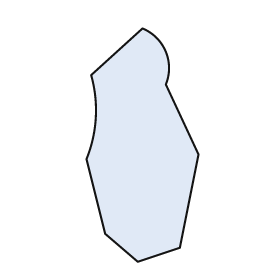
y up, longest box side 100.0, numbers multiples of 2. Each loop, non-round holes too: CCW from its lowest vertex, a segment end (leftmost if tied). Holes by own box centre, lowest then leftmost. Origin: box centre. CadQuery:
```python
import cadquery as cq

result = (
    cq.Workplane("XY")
    .moveTo(-2.0, -50.0)
    .lineTo(16.0, -44.0)
    .lineTo(24.0, -4.0)
    .lineTo(10.0, 26.0)
    .threePointArc((10.0, 40.0), (0.0, 50.0))
    .lineTo(-22.0, 30.0)
    .threePointArc((-20.0, 12.0), (-24.0, -6.0))
    .lineTo(-16.0, -38.0)
    .close()
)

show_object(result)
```